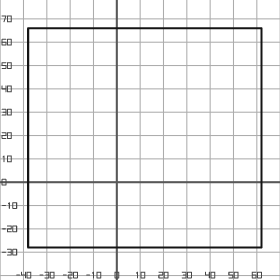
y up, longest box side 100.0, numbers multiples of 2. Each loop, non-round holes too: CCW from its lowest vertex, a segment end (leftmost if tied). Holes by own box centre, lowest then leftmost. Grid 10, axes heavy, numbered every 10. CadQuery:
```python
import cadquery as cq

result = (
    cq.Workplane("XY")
    .moveTo(-38.0, -28.0)
    .lineTo(62.0, -28.0)
    .lineTo(62.0, 66.0)
    .lineTo(-38.0, 66.0)
    .close()
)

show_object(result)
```